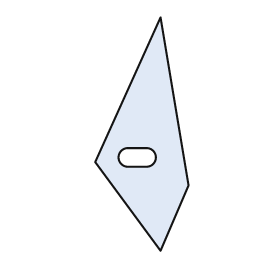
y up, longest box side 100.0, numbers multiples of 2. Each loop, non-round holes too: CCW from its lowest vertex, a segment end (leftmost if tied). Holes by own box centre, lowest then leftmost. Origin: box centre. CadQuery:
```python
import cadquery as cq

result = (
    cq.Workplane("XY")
    .moveTo(8.0, -50.0)
    .lineTo(20.0, -22.0)
    .lineTo(8.0, 50.0)
    .lineTo(-20.0, -12.0)
    .close()
    .moveTo(-6.0, -14.0)
    .lineTo(2.0, -14.0)
    .threePointArc((6.0, -10.0), (2.0, -6.0))
    .lineTo(-6.0, -6.0)
    .threePointArc((-10.0, -10.0), (-6.0, -14.0))
    .close()
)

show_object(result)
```